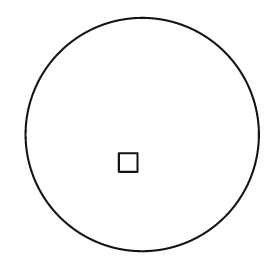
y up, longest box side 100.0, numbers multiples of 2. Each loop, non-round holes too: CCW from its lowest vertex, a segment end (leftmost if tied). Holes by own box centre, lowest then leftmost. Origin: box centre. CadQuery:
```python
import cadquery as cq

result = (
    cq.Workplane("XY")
    .moveTo(0.0, 0.0)
    .circle(50.0)
    .moveTo(-10.0, -16.0)
    .lineTo(-2.0, -16.0)
    .lineTo(-2.0, -8.0)
    .lineTo(-10.0, -8.0)
    .close()
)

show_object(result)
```